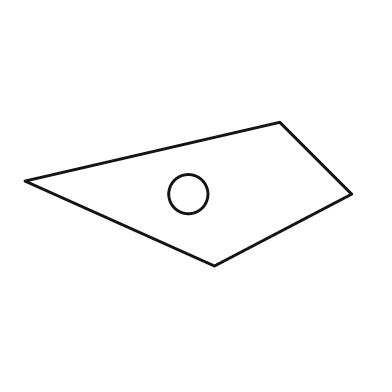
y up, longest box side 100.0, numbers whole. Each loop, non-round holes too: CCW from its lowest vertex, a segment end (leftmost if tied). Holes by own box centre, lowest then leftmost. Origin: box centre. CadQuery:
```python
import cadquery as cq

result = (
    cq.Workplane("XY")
    .moveTo(8.0, -22.0)
    .lineTo(50.0, 0.0)
    .lineTo(28.0, 22.0)
    .lineTo(-50.0, 4.0)
    .close()
    .moveTo(0.0, 0.0)
    .circle(6.0)
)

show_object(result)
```